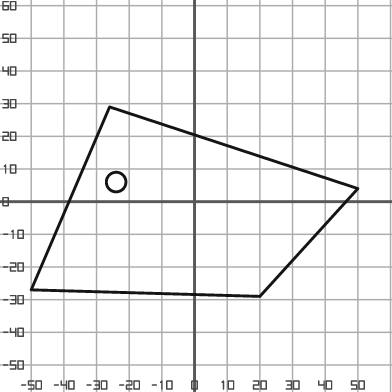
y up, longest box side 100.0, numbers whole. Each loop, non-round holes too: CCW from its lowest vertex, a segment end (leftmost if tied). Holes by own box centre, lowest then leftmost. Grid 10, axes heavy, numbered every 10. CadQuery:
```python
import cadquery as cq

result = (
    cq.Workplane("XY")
    .moveTo(20.0, -29.0)
    .lineTo(50.0, 4.0)
    .lineTo(-26.0, 29.0)
    .lineTo(-50.0, -27.0)
    .close()
    .moveTo(-24.0, 6.0)
    .circle(3.0)
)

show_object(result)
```